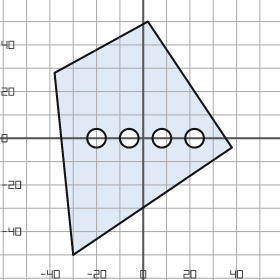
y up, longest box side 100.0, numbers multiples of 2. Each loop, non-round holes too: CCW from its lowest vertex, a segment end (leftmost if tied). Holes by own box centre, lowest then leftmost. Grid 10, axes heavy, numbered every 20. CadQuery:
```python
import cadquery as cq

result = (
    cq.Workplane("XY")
    .moveTo(-30.0, -50.0)
    .lineTo(38.0, -4.0)
    .lineTo(2.0, 50.0)
    .lineTo(-38.0, 28.0)
    .close()
    .moveTo(-20.0, 0.0)
    .circle(4.0)
    .moveTo(-6.0, 0.0)
    .circle(4.0)
    .moveTo(8.0, 0.0)
    .circle(4.0)
    .moveTo(22.0, 0.0)
    .circle(4.0)
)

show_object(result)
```